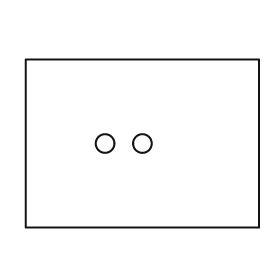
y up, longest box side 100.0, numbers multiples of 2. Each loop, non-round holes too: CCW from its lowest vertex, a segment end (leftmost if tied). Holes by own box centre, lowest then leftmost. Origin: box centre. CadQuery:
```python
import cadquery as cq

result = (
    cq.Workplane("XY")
    .moveTo(-50.0, -36.0)
    .lineTo(50.0, -36.0)
    .lineTo(50.0, 36.0)
    .lineTo(-50.0, 36.0)
    .close()
    .moveTo(-16.0, 0.0)
    .circle(4.0)
    .moveTo(0.0, 0.0)
    .circle(4.0)
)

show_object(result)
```